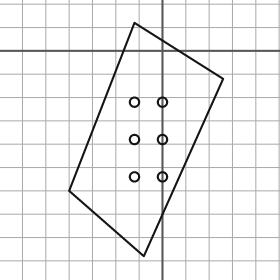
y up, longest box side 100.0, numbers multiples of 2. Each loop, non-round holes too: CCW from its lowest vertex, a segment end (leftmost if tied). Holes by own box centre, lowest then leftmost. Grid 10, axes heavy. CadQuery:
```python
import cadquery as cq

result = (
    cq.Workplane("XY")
    .moveTo(-8.0, -88.0)
    .lineTo(26.0, -12.0)
    .lineTo(-12.0, 12.0)
    .lineTo(-40.0, -60.0)
    .close()
    .moveTo(-12.0, -54.0)
    .circle(2.0)
    .moveTo(0.0, -54.0)
    .circle(2.0)
    .moveTo(-12.0, -38.0)
    .circle(2.0)
    .moveTo(0.0, -38.0)
    .circle(2.0)
    .moveTo(-12.0, -22.0)
    .circle(2.0)
    .moveTo(0.0, -22.0)
    .circle(2.0)
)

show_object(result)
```